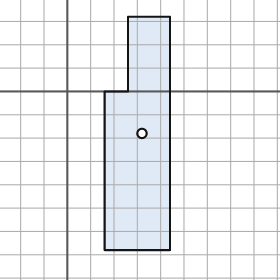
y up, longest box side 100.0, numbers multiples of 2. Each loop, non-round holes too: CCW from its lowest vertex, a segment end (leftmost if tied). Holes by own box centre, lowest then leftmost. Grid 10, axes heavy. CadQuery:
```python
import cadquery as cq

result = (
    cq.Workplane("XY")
    .moveTo(16.0, -68.0)
    .lineTo(44.0, -68.0)
    .lineTo(44.0, 32.0)
    .lineTo(26.0, 32.0)
    .lineTo(26.0, 0.0)
    .lineTo(16.0, 0.0)
    .close()
    .moveTo(32.0, -18.0)
    .circle(2.0)
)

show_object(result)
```